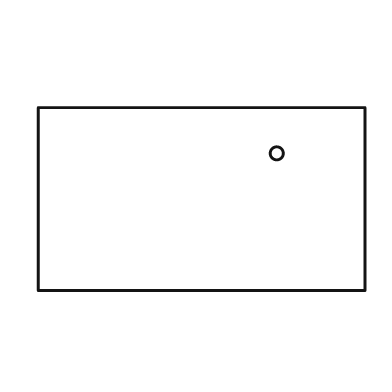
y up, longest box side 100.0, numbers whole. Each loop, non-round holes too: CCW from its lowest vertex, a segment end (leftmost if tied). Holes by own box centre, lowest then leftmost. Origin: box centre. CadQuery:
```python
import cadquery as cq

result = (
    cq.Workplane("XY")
    .moveTo(-50.0, -28.0)
    .lineTo(50.0, -28.0)
    .lineTo(50.0, 28.0)
    .lineTo(-50.0, 28.0)
    .close()
    .moveTo(23.0, 14.0)
    .circle(2.0)
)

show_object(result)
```